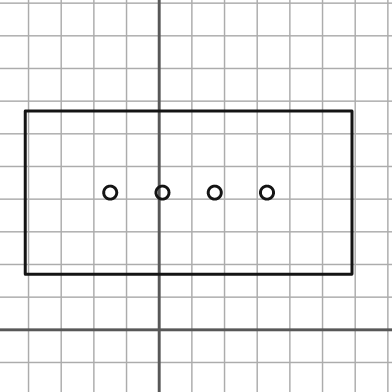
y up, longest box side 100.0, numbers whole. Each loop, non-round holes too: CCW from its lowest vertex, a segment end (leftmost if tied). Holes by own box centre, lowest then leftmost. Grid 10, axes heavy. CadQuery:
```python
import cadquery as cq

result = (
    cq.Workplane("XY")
    .moveTo(-41.0, 17.0)
    .lineTo(59.0, 17.0)
    .lineTo(59.0, 67.0)
    .lineTo(-41.0, 67.0)
    .close()
    .moveTo(-15.0, 42.0)
    .circle(2.0)
    .moveTo(1.0, 42.0)
    .circle(2.0)
    .moveTo(17.0, 42.0)
    .circle(2.0)
    .moveTo(33.0, 42.0)
    .circle(2.0)
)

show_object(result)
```